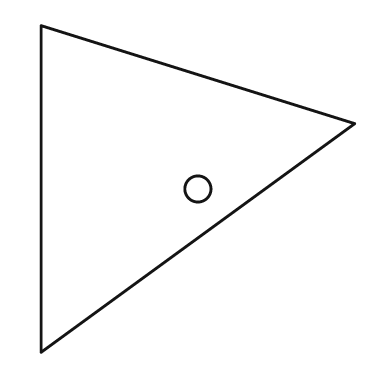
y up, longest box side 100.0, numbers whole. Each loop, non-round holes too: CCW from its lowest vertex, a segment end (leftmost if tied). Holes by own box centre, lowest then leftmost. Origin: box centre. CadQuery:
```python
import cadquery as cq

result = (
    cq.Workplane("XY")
    .moveTo(-48.0, -50.0)
    .lineTo(48.0, 20.0)
    .lineTo(-48.0, 50.0)
    .close()
    .moveTo(0.0, 0.0)
    .circle(4.0)
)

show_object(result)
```